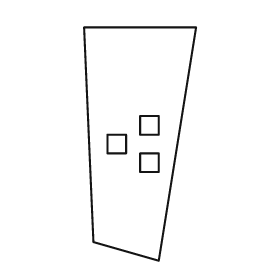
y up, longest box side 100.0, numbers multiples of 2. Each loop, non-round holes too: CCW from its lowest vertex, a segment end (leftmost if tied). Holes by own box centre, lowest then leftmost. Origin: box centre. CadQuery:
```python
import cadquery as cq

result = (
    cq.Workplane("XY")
    .moveTo(8.0, -50.0)
    .lineTo(24.0, 50.0)
    .lineTo(-24.0, 50.0)
    .lineTo(-20.0, -42.0)
    .close()
    .moveTo(0.0, -12.0)
    .lineTo(8.0, -12.0)
    .lineTo(8.0, -4.0)
    .lineTo(0.0, -4.0)
    .close()
    .moveTo(-14.0, -4.0)
    .lineTo(-6.0, -4.0)
    .lineTo(-6.0, 4.0)
    .lineTo(-14.0, 4.0)
    .close()
    .moveTo(0.0, 4.0)
    .lineTo(8.0, 4.0)
    .lineTo(8.0, 12.0)
    .lineTo(0.0, 12.0)
    .close()
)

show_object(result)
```